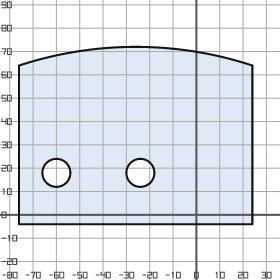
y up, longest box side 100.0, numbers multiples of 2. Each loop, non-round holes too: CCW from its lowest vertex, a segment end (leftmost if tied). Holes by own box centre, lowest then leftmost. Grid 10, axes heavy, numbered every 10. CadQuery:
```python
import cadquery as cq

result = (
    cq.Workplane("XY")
    .moveTo(-76.0, -4.0)
    .lineTo(24.0, -4.0)
    .lineTo(24.0, 64.0)
    .threePointArc((-26.0, 72.0), (-76.0, 64.0))
    .close()
    .moveTo(-60.0, 18.0)
    .circle(6.0)
    .moveTo(-24.0, 18.0)
    .circle(6.0)
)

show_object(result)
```